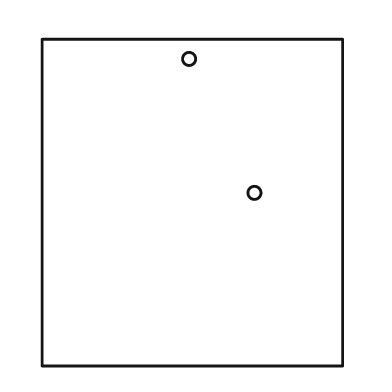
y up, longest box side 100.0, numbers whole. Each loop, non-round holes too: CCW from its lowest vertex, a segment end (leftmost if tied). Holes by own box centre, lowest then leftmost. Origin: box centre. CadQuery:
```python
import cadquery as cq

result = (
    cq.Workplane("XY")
    .moveTo(-46.0, -50.0)
    .lineTo(46.0, -50.0)
    .lineTo(46.0, 50.0)
    .lineTo(-46.0, 50.0)
    .close()
    .moveTo(19.0, 3.0)
    .circle(2.0)
    .moveTo(-1.0, 44.0)
    .circle(2.0)
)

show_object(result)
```